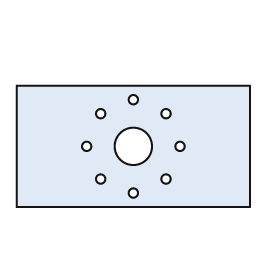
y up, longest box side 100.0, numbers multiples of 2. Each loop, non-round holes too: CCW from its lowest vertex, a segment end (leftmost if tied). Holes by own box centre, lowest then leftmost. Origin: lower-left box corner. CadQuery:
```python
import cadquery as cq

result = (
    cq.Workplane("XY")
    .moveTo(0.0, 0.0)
    .lineTo(100.0, 0.0)
    .lineTo(100.0, 52.0)
    .lineTo(0.0, 52.0)
    .close()
    .moveTo(50.0, 6.0)
    .circle(2.0)
    .moveTo(36.0, 12.0)
    .circle(2.0)
    .moveTo(64.0, 12.0)
    .circle(2.0)
    .moveTo(30.0, 26.0)
    .circle(2.0)
    .moveTo(50.0, 26.0)
    .circle(8.0)
    .moveTo(70.0, 26.0)
    .circle(2.0)
    .moveTo(36.0, 40.0)
    .circle(2.0)
    .moveTo(64.0, 40.0)
    .circle(2.0)
    .moveTo(50.0, 46.0)
    .circle(2.0)
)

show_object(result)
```